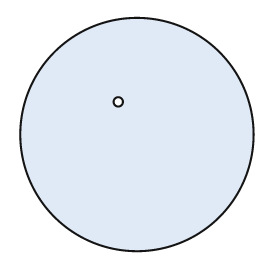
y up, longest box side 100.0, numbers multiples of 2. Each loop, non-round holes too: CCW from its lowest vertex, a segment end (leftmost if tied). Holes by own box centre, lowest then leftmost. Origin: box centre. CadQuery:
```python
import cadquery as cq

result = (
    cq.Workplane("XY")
    .moveTo(0.0, 0.0)
    .circle(50.0)
    .moveTo(-8.0, 14.0)
    .circle(2.0)
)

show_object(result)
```